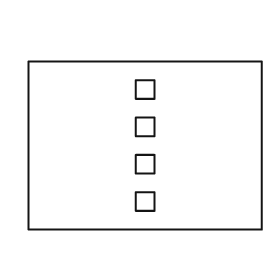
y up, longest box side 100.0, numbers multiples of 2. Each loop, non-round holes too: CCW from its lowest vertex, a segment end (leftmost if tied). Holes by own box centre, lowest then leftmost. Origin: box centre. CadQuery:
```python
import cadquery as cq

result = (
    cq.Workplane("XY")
    .moveTo(-50.0, -36.0)
    .lineTo(50.0, -36.0)
    .lineTo(50.0, 36.0)
    .lineTo(-50.0, 36.0)
    .close()
    .moveTo(-4.0, -28.0)
    .lineTo(4.0, -28.0)
    .lineTo(4.0, -20.0)
    .lineTo(-4.0, -20.0)
    .close()
    .moveTo(-4.0, -12.0)
    .lineTo(4.0, -12.0)
    .lineTo(4.0, -4.0)
    .lineTo(-4.0, -4.0)
    .close()
    .moveTo(-4.0, 4.0)
    .lineTo(4.0, 4.0)
    .lineTo(4.0, 12.0)
    .lineTo(-4.0, 12.0)
    .close()
    .moveTo(-4.0, 20.0)
    .lineTo(4.0, 20.0)
    .lineTo(4.0, 28.0)
    .lineTo(-4.0, 28.0)
    .close()
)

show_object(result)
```